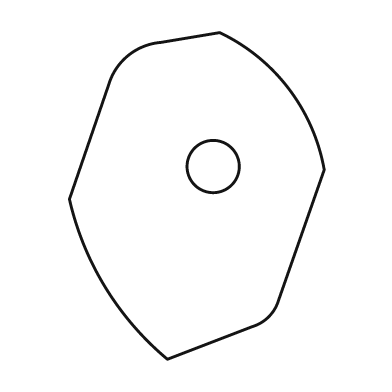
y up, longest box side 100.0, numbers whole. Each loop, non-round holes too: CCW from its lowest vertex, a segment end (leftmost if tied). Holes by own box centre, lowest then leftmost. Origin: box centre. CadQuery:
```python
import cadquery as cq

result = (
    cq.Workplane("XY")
    .moveTo(-9.0, -50.0)
    .lineTo(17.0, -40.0)
    .threePointArc((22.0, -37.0), (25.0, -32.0))
    .lineTo(39.0, 8.0)
    .threePointArc((28.0, 33.0), (7.0, 50.0))
    .lineTo(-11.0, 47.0)
    .threePointArc((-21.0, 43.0), (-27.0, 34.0))
    .lineTo(-39.0, -1.0)
    .threePointArc((-28.0, -28.0), (-9.0, -50.0))
    .close()
    .moveTo(5.0, 9.0)
    .circle(8.0)
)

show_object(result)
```